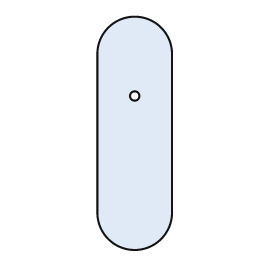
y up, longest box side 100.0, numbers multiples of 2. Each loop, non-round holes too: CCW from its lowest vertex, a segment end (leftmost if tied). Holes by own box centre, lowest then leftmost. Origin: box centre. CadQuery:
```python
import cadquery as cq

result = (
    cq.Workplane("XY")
    .moveTo(-16.0, -34.0)
    .threePointArc((0.0, -50.0), (16.0, -34.0))
    .lineTo(16.0, 34.0)
    .threePointArc((0.0, 50.0), (-16.0, 34.0))
    .close()
    .moveTo(0.0, 16.0)
    .circle(2.0)
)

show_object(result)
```